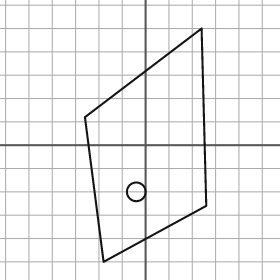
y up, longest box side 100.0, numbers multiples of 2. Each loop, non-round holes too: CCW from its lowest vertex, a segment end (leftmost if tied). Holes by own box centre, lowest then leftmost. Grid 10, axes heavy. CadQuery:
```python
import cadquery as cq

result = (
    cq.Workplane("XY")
    .moveTo(-18.0, -50.0)
    .lineTo(26.0, -26.0)
    .lineTo(24.0, 50.0)
    .lineTo(-26.0, 12.0)
    .close()
    .moveTo(-4.0, -20.0)
    .circle(4.0)
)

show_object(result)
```